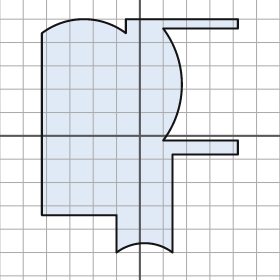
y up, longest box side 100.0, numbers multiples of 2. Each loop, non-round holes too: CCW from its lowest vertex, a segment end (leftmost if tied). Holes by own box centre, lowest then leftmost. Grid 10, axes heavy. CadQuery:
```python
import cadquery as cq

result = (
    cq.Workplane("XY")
    .moveTo(-10.0, -50.0)
    .threePointArc((2.0, -46.0), (14.0, -50.0))
    .lineTo(14.0, -8.0)
    .lineTo(42.0, -8.0)
    .lineTo(42.0, -2.0)
    .lineTo(10.0, -2.0)
    .threePointArc((18.0, 22.0), (10.0, 46.0))
    .lineTo(42.0, 46.0)
    .lineTo(42.0, 50.0)
    .lineTo(-6.0, 50.0)
    .lineTo(-6.0, 44.0)
    .threePointArc((-24.0, 50.0), (-42.0, 44.0))
    .lineTo(-42.0, -34.0)
    .lineTo(-10.0, -34.0)
    .close()
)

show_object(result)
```